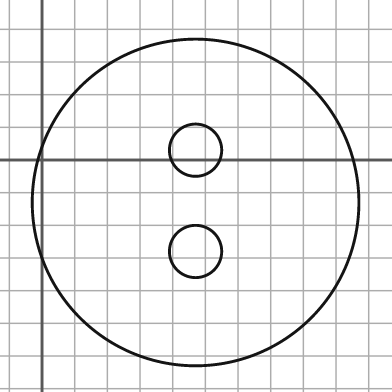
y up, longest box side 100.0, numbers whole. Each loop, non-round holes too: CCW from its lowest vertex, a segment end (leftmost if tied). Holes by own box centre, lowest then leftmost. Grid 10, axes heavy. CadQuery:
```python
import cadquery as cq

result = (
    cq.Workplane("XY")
    .moveTo(47.0, -13.0)
    .circle(50.0)
    .moveTo(47.0, -28.0)
    .circle(8.0)
    .moveTo(47.0, 3.0)
    .circle(8.0)
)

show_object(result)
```